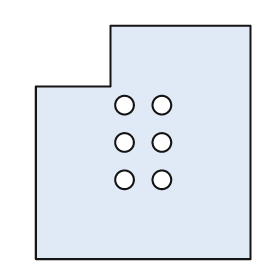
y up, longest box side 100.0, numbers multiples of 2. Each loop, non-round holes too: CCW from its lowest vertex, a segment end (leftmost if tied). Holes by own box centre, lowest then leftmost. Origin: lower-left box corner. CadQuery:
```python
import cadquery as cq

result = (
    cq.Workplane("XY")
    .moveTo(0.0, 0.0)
    .lineTo(92.0, 0.0)
    .lineTo(92.0, 100.0)
    .lineTo(32.0, 100.0)
    .lineTo(32.0, 74.0)
    .lineTo(0.0, 74.0)
    .close()
    .moveTo(38.0, 34.0)
    .circle(4.0)
    .moveTo(54.0, 34.0)
    .circle(4.0)
    .moveTo(38.0, 50.0)
    .circle(4.0)
    .moveTo(54.0, 50.0)
    .circle(4.0)
    .moveTo(38.0, 66.0)
    .circle(4.0)
    .moveTo(54.0, 66.0)
    .circle(4.0)
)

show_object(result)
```